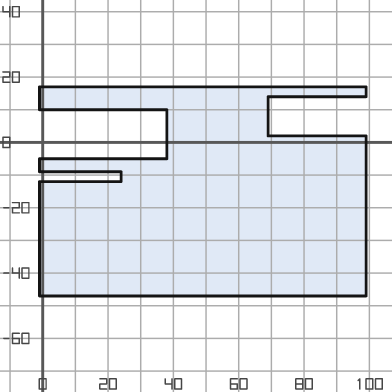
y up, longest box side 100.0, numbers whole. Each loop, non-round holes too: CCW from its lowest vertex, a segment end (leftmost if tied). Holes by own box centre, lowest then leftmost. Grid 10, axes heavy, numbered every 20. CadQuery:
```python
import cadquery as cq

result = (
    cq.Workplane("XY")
    .moveTo(-1.0, -47.0)
    .lineTo(99.0, -47.0)
    .lineTo(99.0, 2.0)
    .lineTo(69.0, 2.0)
    .lineTo(69.0, 14.0)
    .lineTo(99.0, 14.0)
    .lineTo(99.0, 17.0)
    .lineTo(-1.0, 17.0)
    .lineTo(-1.0, 10.0)
    .lineTo(38.0, 10.0)
    .lineTo(38.0, -5.0)
    .lineTo(-1.0, -5.0)
    .lineTo(-1.0, -9.0)
    .lineTo(24.0, -9.0)
    .lineTo(24.0, -12.0)
    .lineTo(-1.0, -12.0)
    .close()
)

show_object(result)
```